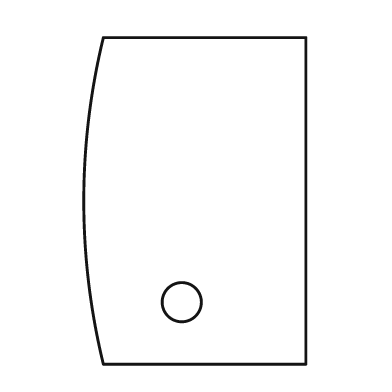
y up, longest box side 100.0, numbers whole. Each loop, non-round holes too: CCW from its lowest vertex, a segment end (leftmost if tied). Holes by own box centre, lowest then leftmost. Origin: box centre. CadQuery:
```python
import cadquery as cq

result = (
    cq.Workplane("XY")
    .moveTo(-28.0, -50.0)
    .lineTo(34.0, -50.0)
    .lineTo(34.0, 50.0)
    .lineTo(-28.0, 50.0)
    .threePointArc((-34.0, 0.0), (-28.0, -50.0))
    .close()
    .moveTo(-4.0, -31.0)
    .circle(6.0)
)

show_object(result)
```